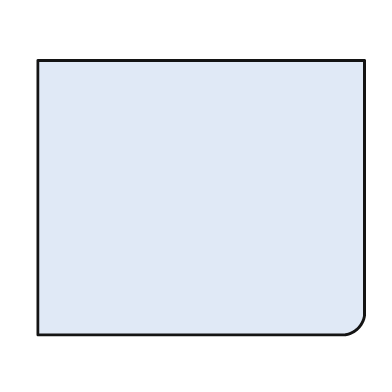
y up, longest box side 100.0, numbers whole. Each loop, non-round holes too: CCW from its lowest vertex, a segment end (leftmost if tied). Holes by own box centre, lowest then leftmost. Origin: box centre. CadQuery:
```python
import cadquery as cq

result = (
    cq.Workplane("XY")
    .moveTo(-50.0, -42.0)
    .lineTo(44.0, -42.0)
    .threePointArc((48.0, -40.0), (50.0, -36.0))
    .lineTo(50.0, 42.0)
    .lineTo(-50.0, 42.0)
    .close()
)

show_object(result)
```